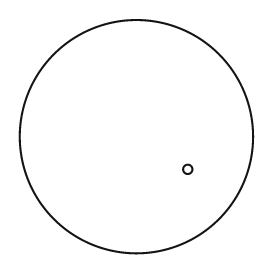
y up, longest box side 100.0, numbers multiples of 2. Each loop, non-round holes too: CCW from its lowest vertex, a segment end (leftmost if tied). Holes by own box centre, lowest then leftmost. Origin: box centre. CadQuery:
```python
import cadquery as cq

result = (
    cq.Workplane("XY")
    .moveTo(0.0, 0.0)
    .circle(50.0)
    .moveTo(22.0, -14.0)
    .circle(2.0)
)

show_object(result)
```